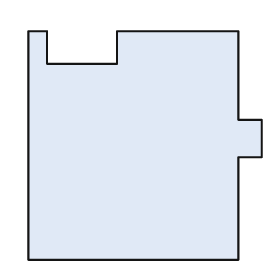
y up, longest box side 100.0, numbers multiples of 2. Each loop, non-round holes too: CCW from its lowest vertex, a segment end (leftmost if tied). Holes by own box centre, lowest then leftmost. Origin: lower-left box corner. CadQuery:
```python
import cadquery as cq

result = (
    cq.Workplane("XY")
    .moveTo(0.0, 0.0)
    .lineTo(90.0, 0.0)
    .lineTo(90.0, 44.0)
    .lineTo(100.0, 44.0)
    .lineTo(100.0, 60.0)
    .lineTo(90.0, 60.0)
    .lineTo(90.0, 98.0)
    .lineTo(38.0, 98.0)
    .lineTo(38.0, 84.0)
    .lineTo(8.0, 84.0)
    .lineTo(8.0, 98.0)
    .lineTo(0.0, 98.0)
    .close()
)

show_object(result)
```